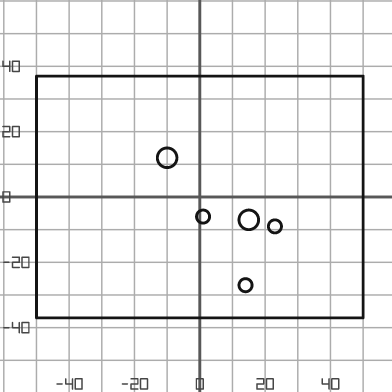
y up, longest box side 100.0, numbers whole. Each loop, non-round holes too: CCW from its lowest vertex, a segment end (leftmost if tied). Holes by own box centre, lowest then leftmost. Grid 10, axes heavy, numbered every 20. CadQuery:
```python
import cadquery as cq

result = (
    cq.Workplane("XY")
    .moveTo(-50.0, -37.0)
    .lineTo(50.0, -37.0)
    .lineTo(50.0, 37.0)
    .lineTo(-50.0, 37.0)
    .close()
    .moveTo(14.0, -27.0)
    .circle(2.0)
    .moveTo(23.0, -9.0)
    .circle(2.0)
    .moveTo(15.0, -7.0)
    .circle(3.0)
    .moveTo(1.0, -6.0)
    .circle(2.0)
    .moveTo(-10.0, 12.0)
    .circle(3.0)
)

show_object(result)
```